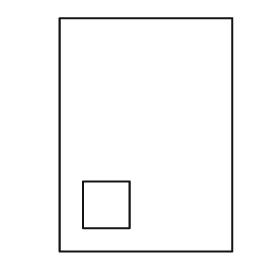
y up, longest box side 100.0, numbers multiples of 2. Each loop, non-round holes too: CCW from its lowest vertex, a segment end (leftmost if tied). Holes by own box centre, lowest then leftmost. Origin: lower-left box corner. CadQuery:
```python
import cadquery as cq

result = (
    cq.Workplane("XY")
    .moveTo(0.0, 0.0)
    .lineTo(74.0, 0.0)
    .lineTo(74.0, 100.0)
    .lineTo(0.0, 100.0)
    .close()
    .moveTo(10.0, 10.0)
    .lineTo(30.0, 10.0)
    .lineTo(30.0, 30.0)
    .lineTo(10.0, 30.0)
    .close()
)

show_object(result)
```